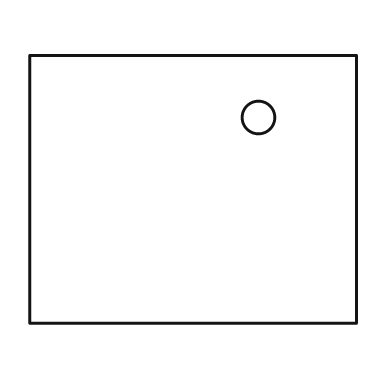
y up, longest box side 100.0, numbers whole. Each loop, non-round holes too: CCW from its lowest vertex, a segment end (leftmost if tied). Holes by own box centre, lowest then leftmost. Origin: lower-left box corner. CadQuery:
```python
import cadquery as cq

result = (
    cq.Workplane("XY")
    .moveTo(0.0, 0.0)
    .lineTo(100.0, 0.0)
    .lineTo(100.0, 82.0)
    .lineTo(0.0, 82.0)
    .close()
    .moveTo(70.0, 63.0)
    .circle(5.0)
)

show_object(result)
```